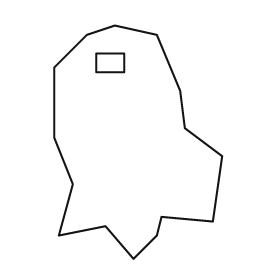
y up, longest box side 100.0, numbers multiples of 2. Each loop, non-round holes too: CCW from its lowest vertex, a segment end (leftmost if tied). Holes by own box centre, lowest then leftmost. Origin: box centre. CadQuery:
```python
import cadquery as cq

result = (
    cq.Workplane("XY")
    .moveTo(-2.0, -50.0)
    .lineTo(8.0, -40.0)
    .lineTo(10.0, -32.0)
    .lineTo(32.0, -34.0)
    .lineTo(36.0, -6.0)
    .lineTo(20.0, 6.0)
    .lineTo(18.0, 22.0)
    .lineTo(8.0, 46.0)
    .lineTo(-10.0, 50.0)
    .lineTo(-22.0, 46.0)
    .lineTo(-36.0, 32.0)
    .lineTo(-36.0, 2.0)
    .lineTo(-28.0, -18.0)
    .lineTo(-34.0, -40.0)
    .lineTo(-14.0, -36.0)
    .close()
    .moveTo(-18.0, 30.0)
    .lineTo(-6.0, 30.0)
    .lineTo(-6.0, 38.0)
    .lineTo(-18.0, 38.0)
    .close()
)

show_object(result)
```